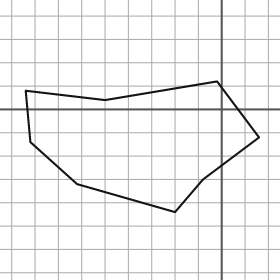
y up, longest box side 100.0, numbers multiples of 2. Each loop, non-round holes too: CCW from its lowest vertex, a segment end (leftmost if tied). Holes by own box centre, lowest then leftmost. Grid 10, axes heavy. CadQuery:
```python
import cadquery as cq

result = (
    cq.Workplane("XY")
    .moveTo(-20.0, -44.0)
    .lineTo(-8.0, -30.0)
    .lineTo(16.0, -12.0)
    .lineTo(-2.0, 12.0)
    .lineTo(-50.0, 4.0)
    .lineTo(-84.0, 8.0)
    .lineTo(-82.0, -14.0)
    .lineTo(-62.0, -32.0)
    .close()
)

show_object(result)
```